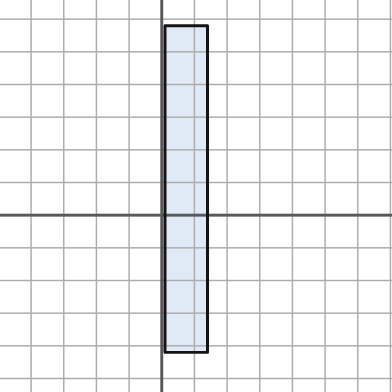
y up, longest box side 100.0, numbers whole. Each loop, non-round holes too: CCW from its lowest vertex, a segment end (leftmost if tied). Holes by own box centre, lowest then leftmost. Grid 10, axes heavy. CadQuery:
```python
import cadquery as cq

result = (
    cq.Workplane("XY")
    .moveTo(1.0, -42.0)
    .lineTo(14.0, -42.0)
    .lineTo(14.0, 58.0)
    .lineTo(1.0, 58.0)
    .close()
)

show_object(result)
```